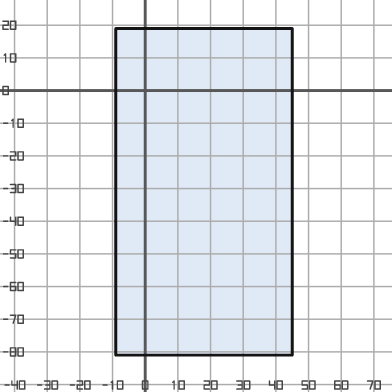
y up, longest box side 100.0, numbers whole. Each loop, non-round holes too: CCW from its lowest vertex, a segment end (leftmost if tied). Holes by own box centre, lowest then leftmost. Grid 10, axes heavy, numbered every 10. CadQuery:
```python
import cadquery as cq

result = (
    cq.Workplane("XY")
    .moveTo(-9.0, -81.0)
    .lineTo(45.0, -81.0)
    .lineTo(45.0, 19.0)
    .lineTo(-9.0, 19.0)
    .close()
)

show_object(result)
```